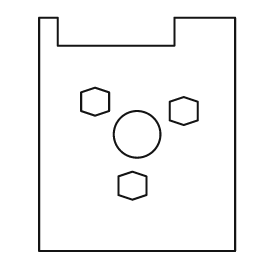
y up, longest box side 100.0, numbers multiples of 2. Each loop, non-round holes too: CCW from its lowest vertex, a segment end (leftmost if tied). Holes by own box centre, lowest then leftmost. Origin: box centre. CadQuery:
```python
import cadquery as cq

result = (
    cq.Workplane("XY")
    .moveTo(-42.0, -50.0)
    .lineTo(42.0, -50.0)
    .lineTo(42.0, 50.0)
    .lineTo(16.0, 50.0)
    .lineTo(16.0, 38.0)
    .lineTo(-34.0, 38.0)
    .lineTo(-34.0, 50.0)
    .lineTo(-42.0, 50.0)
    .close()
    .moveTo(-2.0, -28.0)
    .lineTo(4.0, -26.0)
    .lineTo(4.0, -18.0)
    .lineTo(-2.0, -16.0)
    .lineTo(-8.0, -18.0)
    .lineTo(-8.0, -26.0)
    .close()
    .moveTo(0.0, 0.0)
    .circle(10.0)
    .moveTo(20.0, 4.0)
    .lineTo(26.0, 6.0)
    .lineTo(26.0, 14.0)
    .lineTo(20.0, 16.0)
    .lineTo(14.0, 14.0)
    .lineTo(14.0, 6.0)
    .close()
    .moveTo(-18.0, 8.0)
    .lineTo(-12.0, 10.0)
    .lineTo(-12.0, 18.0)
    .lineTo(-18.0, 20.0)
    .lineTo(-24.0, 18.0)
    .lineTo(-24.0, 10.0)
    .close()
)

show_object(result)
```